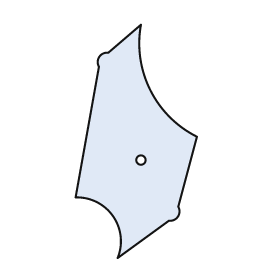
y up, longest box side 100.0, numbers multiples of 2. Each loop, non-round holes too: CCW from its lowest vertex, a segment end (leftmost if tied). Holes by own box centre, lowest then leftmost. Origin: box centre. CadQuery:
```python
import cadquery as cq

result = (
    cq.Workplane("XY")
    .moveTo(-8.0, -50.0)
    .lineTo(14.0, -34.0)
    .threePointArc((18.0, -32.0), (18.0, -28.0))
    .lineTo(26.0, 2.0)
    .threePointArc((6.0, 22.0), (2.0, 50.0))
    .lineTo(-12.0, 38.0)
    .threePointArc((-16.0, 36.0), (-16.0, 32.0))
    .lineTo(-26.0, -24.0)
    .threePointArc((-10.0, -32.0), (-8.0, -50.0))
    .close()
    .moveTo(2.0, -8.0)
    .circle(2.0)
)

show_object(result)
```